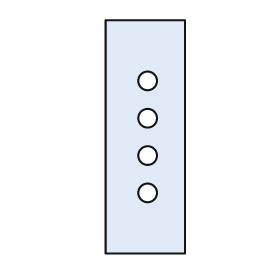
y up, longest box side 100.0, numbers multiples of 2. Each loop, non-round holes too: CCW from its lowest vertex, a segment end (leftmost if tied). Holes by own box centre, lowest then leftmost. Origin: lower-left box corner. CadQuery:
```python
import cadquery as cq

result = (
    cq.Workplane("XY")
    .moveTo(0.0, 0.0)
    .lineTo(34.0, 0.0)
    .lineTo(34.0, 100.0)
    .lineTo(0.0, 100.0)
    .close()
    .moveTo(18.0, 26.0)
    .circle(4.0)
    .moveTo(18.0, 42.0)
    .circle(4.0)
    .moveTo(18.0, 58.0)
    .circle(4.0)
    .moveTo(18.0, 74.0)
    .circle(4.0)
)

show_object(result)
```